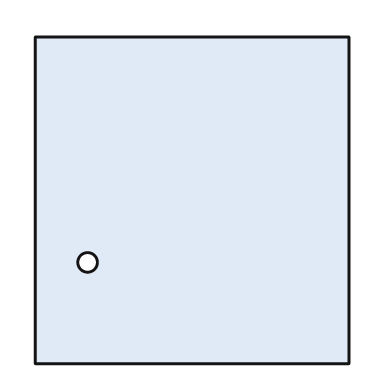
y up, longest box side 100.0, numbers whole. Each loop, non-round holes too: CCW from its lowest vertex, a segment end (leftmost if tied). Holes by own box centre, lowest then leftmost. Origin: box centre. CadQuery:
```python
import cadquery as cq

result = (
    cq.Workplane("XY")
    .moveTo(-48.0, -50.0)
    .lineTo(48.0, -50.0)
    .lineTo(48.0, 50.0)
    .lineTo(-48.0, 50.0)
    .close()
    .moveTo(-32.0, -19.0)
    .circle(3.0)
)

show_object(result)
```